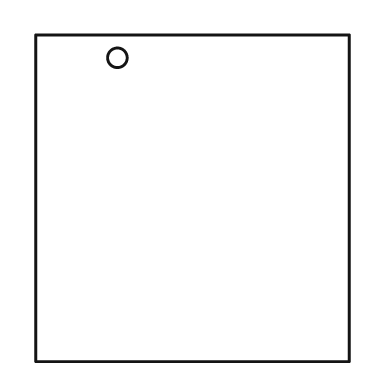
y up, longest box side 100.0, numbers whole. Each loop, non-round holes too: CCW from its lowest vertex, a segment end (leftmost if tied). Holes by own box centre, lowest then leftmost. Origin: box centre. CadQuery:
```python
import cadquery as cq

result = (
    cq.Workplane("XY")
    .moveTo(-48.0, -50.0)
    .lineTo(48.0, -50.0)
    .lineTo(48.0, 50.0)
    .lineTo(-48.0, 50.0)
    .close()
    .moveTo(-23.0, 43.0)
    .circle(3.0)
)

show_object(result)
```